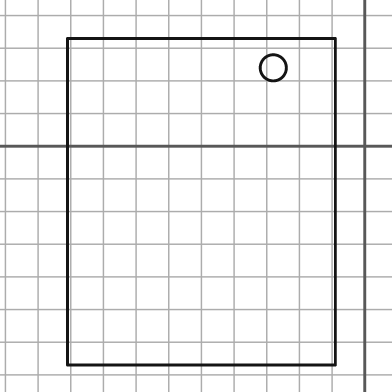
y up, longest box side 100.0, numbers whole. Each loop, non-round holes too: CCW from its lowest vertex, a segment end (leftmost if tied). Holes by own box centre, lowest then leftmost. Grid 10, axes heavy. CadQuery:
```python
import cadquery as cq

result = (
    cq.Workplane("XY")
    .moveTo(-91.0, -67.0)
    .lineTo(-9.0, -67.0)
    .lineTo(-9.0, 33.0)
    .lineTo(-91.0, 33.0)
    .close()
    .moveTo(-28.0, 24.0)
    .circle(4.0)
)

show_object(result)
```